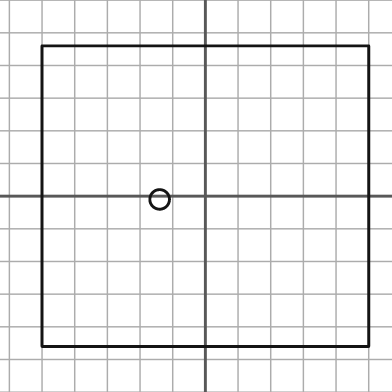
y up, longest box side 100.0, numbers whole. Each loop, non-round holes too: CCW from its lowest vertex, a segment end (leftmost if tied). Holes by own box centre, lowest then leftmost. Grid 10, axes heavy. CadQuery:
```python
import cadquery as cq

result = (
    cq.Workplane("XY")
    .moveTo(-50.0, -46.0)
    .lineTo(50.0, -46.0)
    .lineTo(50.0, 46.0)
    .lineTo(-50.0, 46.0)
    .close()
    .moveTo(-14.0, -1.0)
    .circle(3.0)
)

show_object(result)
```